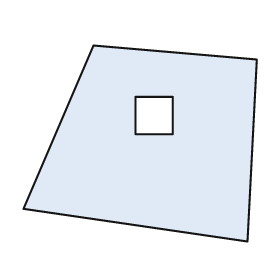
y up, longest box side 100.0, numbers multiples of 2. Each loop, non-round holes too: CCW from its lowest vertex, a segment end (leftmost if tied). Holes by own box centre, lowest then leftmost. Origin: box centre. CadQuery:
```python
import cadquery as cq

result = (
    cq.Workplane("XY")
    .moveTo(46.0, -42.0)
    .lineTo(50.0, 36.0)
    .lineTo(-20.0, 42.0)
    .lineTo(-50.0, -28.0)
    .close()
    .moveTo(-2.0, 4.0)
    .lineTo(14.0, 4.0)
    .lineTo(14.0, 20.0)
    .lineTo(-2.0, 20.0)
    .close()
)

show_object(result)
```